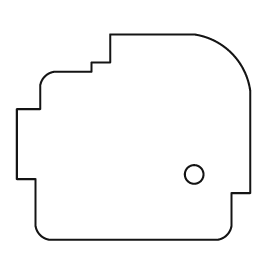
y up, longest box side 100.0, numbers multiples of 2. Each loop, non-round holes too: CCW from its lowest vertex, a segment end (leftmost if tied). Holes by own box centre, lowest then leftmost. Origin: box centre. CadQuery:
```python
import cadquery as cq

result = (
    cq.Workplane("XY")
    .moveTo(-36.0, -44.0)
    .lineTo(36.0, -44.0)
    .threePointArc((40.0, -42.0), (42.0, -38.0))
    .lineTo(42.0, -24.0)
    .lineTo(50.0, -24.0)
    .lineTo(50.0, 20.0)
    .threePointArc((42.0, 36.0), (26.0, 44.0))
    .lineTo(-10.0, 44.0)
    .lineTo(-10.0, 32.0)
    .lineTo(-18.0, 32.0)
    .lineTo(-18.0, 28.0)
    .lineTo(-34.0, 28.0)
    .threePointArc((-38.0, 26.0), (-40.0, 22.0))
    .lineTo(-40.0, 12.0)
    .lineTo(-50.0, 12.0)
    .lineTo(-50.0, -18.0)
    .lineTo(-42.0, -18.0)
    .lineTo(-42.0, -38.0)
    .threePointArc((-40.0, -42.0), (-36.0, -44.0))
    .close()
    .moveTo(26.0, -16.0)
    .circle(4.0)
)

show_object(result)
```